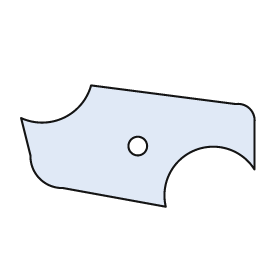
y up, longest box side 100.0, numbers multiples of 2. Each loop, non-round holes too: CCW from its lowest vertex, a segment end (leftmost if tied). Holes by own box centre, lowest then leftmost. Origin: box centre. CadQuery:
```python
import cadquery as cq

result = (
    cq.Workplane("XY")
    .moveTo(12.0, -26.0)
    .threePointArc((24.0, -2.0), (50.0, -10.0))
    .lineTo(50.0, 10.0)
    .threePointArc((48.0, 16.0), (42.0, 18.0))
    .lineTo(-20.0, 26.0)
    .threePointArc((-32.0, 12.0), (-50.0, 12.0))
    .lineTo(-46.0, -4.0)
    .threePointArc((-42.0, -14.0), (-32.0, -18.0))
    .close()
    .moveTo(0.0, 0.0)
    .circle(4.0)
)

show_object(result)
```